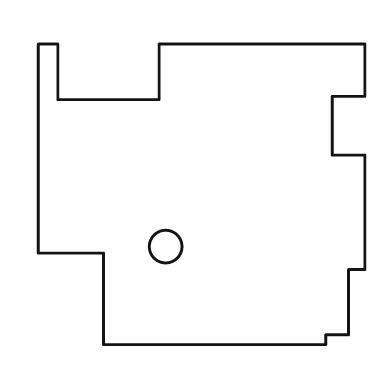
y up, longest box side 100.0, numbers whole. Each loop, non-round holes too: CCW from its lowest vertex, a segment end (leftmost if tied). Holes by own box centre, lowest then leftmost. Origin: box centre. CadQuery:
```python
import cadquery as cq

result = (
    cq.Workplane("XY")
    .moveTo(-30.0, -46.0)
    .lineTo(38.0, -46.0)
    .lineTo(38.0, -43.0)
    .lineTo(45.0, -43.0)
    .lineTo(45.0, -23.0)
    .lineTo(50.0, -23.0)
    .lineTo(50.0, 12.0)
    .lineTo(40.0, 12.0)
    .lineTo(40.0, 30.0)
    .lineTo(50.0, 30.0)
    .lineTo(50.0, 46.0)
    .lineTo(-13.0, 46.0)
    .lineTo(-13.0, 29.0)
    .lineTo(-44.0, 29.0)
    .lineTo(-44.0, 46.0)
    .lineTo(-50.0, 46.0)
    .lineTo(-50.0, -18.0)
    .lineTo(-30.0, -18.0)
    .close()
    .moveTo(-11.0, -16.0)
    .circle(5.0)
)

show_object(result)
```